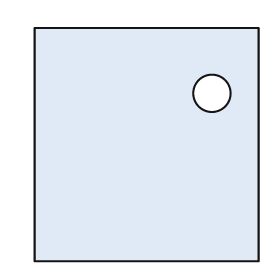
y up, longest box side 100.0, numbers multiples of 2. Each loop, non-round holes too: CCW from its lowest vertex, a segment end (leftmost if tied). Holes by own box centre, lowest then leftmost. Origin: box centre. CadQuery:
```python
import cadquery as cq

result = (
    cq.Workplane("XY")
    .moveTo(-48.0, -50.0)
    .lineTo(48.0, -50.0)
    .lineTo(48.0, 50.0)
    .lineTo(-48.0, 50.0)
    .close()
    .moveTo(28.0, 22.0)
    .circle(8.0)
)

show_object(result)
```